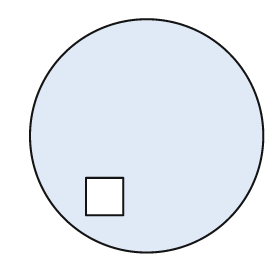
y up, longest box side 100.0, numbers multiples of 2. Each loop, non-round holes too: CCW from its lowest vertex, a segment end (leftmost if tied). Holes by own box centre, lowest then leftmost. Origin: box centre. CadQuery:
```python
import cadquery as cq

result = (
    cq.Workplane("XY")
    .moveTo(0.0, 0.0)
    .circle(50.0)
    .moveTo(-26.0, -34.0)
    .lineTo(-10.0, -34.0)
    .lineTo(-10.0, -18.0)
    .lineTo(-26.0, -18.0)
    .close()
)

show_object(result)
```